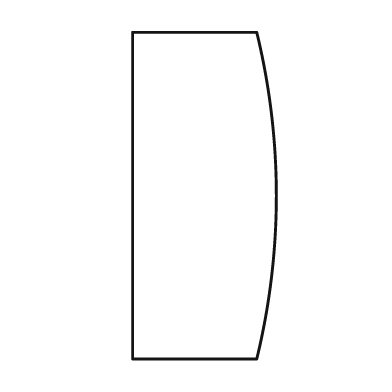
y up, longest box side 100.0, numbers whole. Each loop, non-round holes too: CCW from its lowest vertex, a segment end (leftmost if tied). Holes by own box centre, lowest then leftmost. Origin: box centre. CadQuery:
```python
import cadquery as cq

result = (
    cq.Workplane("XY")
    .moveTo(-22.0, -50.0)
    .lineTo(16.0, -50.0)
    .threePointArc((22.0, 0.0), (16.0, 50.0))
    .lineTo(-22.0, 50.0)
    .close()
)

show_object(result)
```